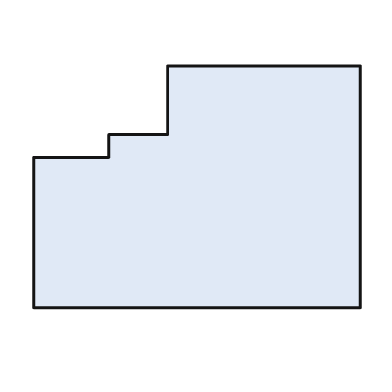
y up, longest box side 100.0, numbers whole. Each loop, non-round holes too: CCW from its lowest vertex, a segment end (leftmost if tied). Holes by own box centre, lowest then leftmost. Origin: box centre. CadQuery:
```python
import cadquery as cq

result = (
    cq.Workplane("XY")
    .moveTo(-50.0, -37.0)
    .lineTo(50.0, -37.0)
    .lineTo(50.0, 37.0)
    .lineTo(-9.0, 37.0)
    .lineTo(-9.0, 16.0)
    .lineTo(-27.0, 16.0)
    .lineTo(-27.0, 9.0)
    .lineTo(-50.0, 9.0)
    .close()
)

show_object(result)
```